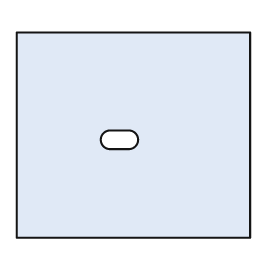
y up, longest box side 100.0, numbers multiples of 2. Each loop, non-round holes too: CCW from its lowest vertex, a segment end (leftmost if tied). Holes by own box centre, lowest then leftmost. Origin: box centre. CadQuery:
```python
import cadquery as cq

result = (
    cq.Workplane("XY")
    .moveTo(-50.0, -44.0)
    .lineTo(50.0, -44.0)
    .lineTo(50.0, 44.0)
    .lineTo(-50.0, 44.0)
    .close()
    .moveTo(-10.0, -6.0)
    .lineTo(-2.0, -6.0)
    .threePointArc((2.0, -2.0), (-2.0, 2.0))
    .lineTo(-10.0, 2.0)
    .threePointArc((-14.0, -2.0), (-10.0, -6.0))
    .close()
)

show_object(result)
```